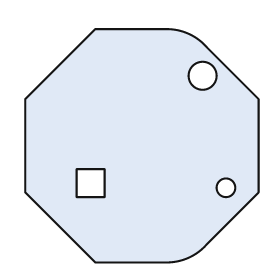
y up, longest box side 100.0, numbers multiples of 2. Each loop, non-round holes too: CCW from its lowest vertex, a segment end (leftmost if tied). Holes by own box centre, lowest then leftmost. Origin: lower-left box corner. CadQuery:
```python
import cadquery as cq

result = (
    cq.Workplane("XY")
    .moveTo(30.0, 0.0)
    .lineTo(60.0, 0.0)
    .threePointArc((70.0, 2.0), (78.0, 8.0))
    .lineTo(100.0, 30.0)
    .lineTo(100.0, 70.0)
    .lineTo(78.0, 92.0)
    .threePointArc((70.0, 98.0), (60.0, 100.0))
    .lineTo(30.0, 100.0)
    .lineTo(0.0, 70.0)
    .lineTo(0.0, 30.0)
    .close()
    .moveTo(86.0, 32.0)
    .circle(4.0)
    .moveTo(22.0, 28.0)
    .lineTo(34.0, 28.0)
    .lineTo(34.0, 40.0)
    .lineTo(22.0, 40.0)
    .close()
    .moveTo(76.0, 80.0)
    .circle(6.0)
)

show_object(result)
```